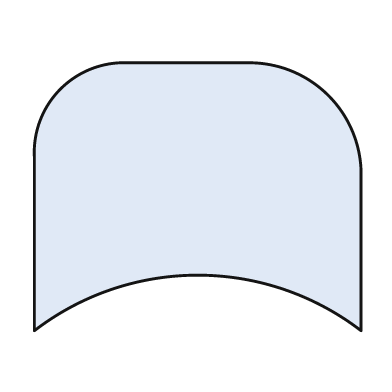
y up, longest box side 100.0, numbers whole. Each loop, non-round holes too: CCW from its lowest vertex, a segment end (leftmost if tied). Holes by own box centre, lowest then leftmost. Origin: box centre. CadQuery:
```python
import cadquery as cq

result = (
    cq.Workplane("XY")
    .moveTo(-50.0, -41.0)
    .threePointArc((0.0, -24.0), (50.0, -41.0))
    .lineTo(50.0, 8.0)
    .threePointArc((40.0, 31.0), (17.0, 41.0))
    .lineTo(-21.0, 41.0)
    .threePointArc((-42.0, 33.0), (-50.0, 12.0))
    .close()
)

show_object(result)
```